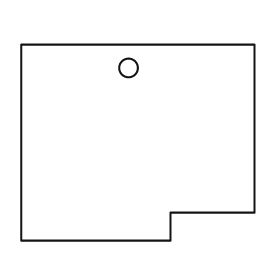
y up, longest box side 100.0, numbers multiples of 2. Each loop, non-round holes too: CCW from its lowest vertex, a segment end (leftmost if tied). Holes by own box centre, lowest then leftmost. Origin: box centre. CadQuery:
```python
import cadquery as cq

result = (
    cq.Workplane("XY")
    .moveTo(-50.0, -42.0)
    .lineTo(14.0, -42.0)
    .lineTo(14.0, -30.0)
    .lineTo(50.0, -30.0)
    .lineTo(50.0, 42.0)
    .lineTo(-50.0, 42.0)
    .close()
    .moveTo(-4.0, 32.0)
    .circle(4.0)
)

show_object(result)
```